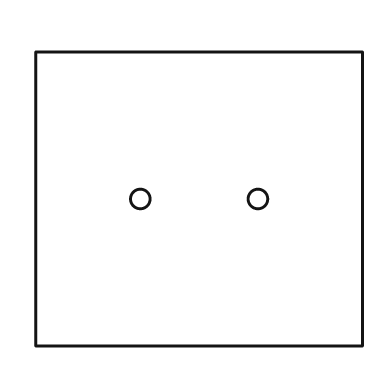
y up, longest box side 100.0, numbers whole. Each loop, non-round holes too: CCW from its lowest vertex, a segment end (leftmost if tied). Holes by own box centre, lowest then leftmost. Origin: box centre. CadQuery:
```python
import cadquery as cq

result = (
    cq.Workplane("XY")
    .moveTo(-50.0, -45.0)
    .lineTo(50.0, -45.0)
    .lineTo(50.0, 45.0)
    .lineTo(-50.0, 45.0)
    .close()
    .moveTo(-18.0, 0.0)
    .circle(3.0)
    .moveTo(18.0, 0.0)
    .circle(3.0)
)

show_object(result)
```